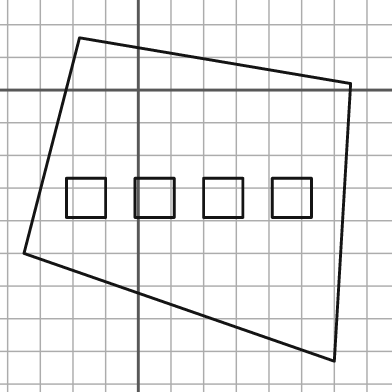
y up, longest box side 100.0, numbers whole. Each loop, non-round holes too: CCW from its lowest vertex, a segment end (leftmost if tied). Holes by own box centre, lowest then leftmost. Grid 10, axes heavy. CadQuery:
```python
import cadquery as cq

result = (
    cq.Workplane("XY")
    .moveTo(60.0, -83.0)
    .lineTo(65.0, 2.0)
    .lineTo(-18.0, 16.0)
    .lineTo(-35.0, -50.0)
    .close()
    .moveTo(-22.0, -39.0)
    .lineTo(-10.0, -39.0)
    .lineTo(-10.0, -27.0)
    .lineTo(-22.0, -27.0)
    .close()
    .moveTo(-1.0, -39.0)
    .lineTo(11.0, -39.0)
    .lineTo(11.0, -27.0)
    .lineTo(-1.0, -27.0)
    .close()
    .moveTo(20.0, -39.0)
    .lineTo(32.0, -39.0)
    .lineTo(32.0, -27.0)
    .lineTo(20.0, -27.0)
    .close()
    .moveTo(41.0, -39.0)
    .lineTo(53.0, -39.0)
    .lineTo(53.0, -27.0)
    .lineTo(41.0, -27.0)
    .close()
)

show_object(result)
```